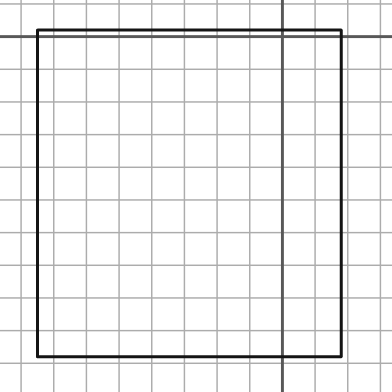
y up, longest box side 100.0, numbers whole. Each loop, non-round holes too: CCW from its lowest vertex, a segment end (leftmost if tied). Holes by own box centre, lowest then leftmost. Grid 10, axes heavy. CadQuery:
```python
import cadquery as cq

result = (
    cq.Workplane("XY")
    .moveTo(-75.0, -98.0)
    .lineTo(18.0, -98.0)
    .lineTo(18.0, 2.0)
    .lineTo(-75.0, 2.0)
    .close()
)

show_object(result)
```